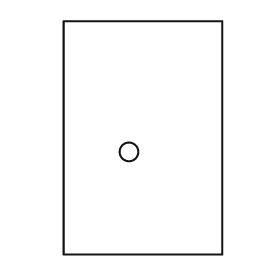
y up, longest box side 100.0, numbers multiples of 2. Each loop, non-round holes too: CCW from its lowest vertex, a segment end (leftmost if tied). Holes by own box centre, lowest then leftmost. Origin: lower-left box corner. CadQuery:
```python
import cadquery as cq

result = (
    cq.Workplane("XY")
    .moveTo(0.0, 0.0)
    .lineTo(68.0, 0.0)
    .lineTo(68.0, 100.0)
    .lineTo(0.0, 100.0)
    .close()
    .moveTo(28.0, 44.0)
    .circle(4.0)
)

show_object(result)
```